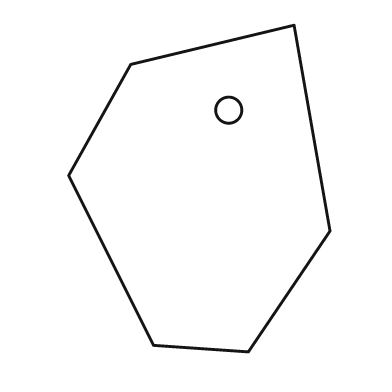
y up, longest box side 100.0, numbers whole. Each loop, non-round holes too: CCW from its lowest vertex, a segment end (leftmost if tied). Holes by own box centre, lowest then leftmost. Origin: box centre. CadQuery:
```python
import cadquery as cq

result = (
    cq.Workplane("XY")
    .moveTo(15.0, -50.0)
    .lineTo(40.0, -13.0)
    .lineTo(29.0, 50.0)
    .lineTo(-21.0, 38.0)
    .lineTo(-40.0, 4.0)
    .lineTo(-14.0, -48.0)
    .close()
    .moveTo(9.0, 24.0)
    .circle(4.0)
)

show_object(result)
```